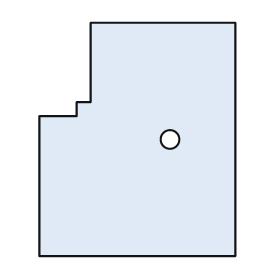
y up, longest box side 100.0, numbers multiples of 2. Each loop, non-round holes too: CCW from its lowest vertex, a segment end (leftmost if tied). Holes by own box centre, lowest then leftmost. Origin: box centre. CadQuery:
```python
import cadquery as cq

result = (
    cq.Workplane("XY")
    .moveTo(-42.0, -50.0)
    .lineTo(42.0, -50.0)
    .lineTo(42.0, 50.0)
    .lineTo(-20.0, 50.0)
    .lineTo(-20.0, 16.0)
    .lineTo(-26.0, 16.0)
    .lineTo(-26.0, 10.0)
    .lineTo(-42.0, 10.0)
    .close()
    .moveTo(14.0, 0.0)
    .circle(4.0)
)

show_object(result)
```